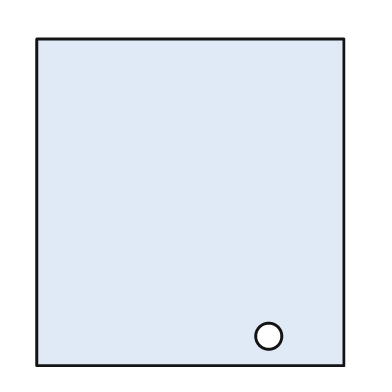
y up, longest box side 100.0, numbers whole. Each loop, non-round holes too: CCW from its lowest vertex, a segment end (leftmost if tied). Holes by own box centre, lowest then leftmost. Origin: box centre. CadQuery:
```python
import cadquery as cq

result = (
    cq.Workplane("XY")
    .moveTo(-47.0, -50.0)
    .lineTo(47.0, -50.0)
    .lineTo(47.0, 50.0)
    .lineTo(-47.0, 50.0)
    .close()
    .moveTo(24.0, -41.0)
    .circle(4.0)
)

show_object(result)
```